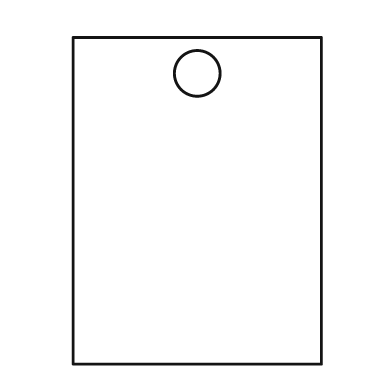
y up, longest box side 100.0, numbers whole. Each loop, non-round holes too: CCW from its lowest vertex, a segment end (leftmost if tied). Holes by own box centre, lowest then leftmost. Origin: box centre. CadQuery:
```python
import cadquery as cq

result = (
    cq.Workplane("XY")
    .moveTo(-38.0, -50.0)
    .lineTo(38.0, -50.0)
    .lineTo(38.0, 50.0)
    .lineTo(-38.0, 50.0)
    .close()
    .moveTo(0.0, 39.0)
    .circle(7.0)
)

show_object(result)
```